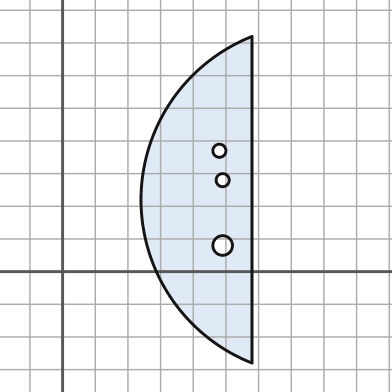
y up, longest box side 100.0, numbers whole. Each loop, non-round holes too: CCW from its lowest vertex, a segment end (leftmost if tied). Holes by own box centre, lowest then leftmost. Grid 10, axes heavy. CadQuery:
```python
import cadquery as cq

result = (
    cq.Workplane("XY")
    .moveTo(58.0, -28.0)
    .lineTo(58.0, 72.0)
    .threePointArc((24.0, 22.0), (58.0, -28.0))
    .close()
    .moveTo(49.0, 8.0)
    .circle(3.0)
    .moveTo(49.0, 28.0)
    .circle(2.0)
    .moveTo(48.0, 37.0)
    .circle(2.0)
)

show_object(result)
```